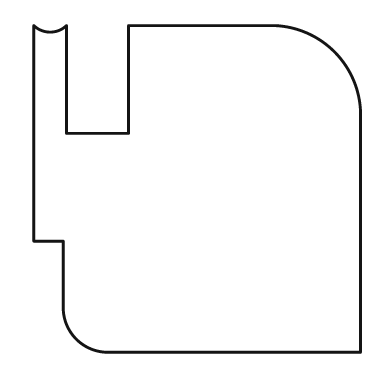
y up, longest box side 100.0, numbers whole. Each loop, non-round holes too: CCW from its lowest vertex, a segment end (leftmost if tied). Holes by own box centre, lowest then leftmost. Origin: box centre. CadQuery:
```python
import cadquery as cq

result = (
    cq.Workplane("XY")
    .moveTo(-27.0, -50.0)
    .lineTo(50.0, -50.0)
    .lineTo(50.0, 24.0)
    .threePointArc((42.0, 42.0), (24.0, 50.0))
    .lineTo(-21.0, 50.0)
    .lineTo(-21.0, 17.0)
    .lineTo(-40.0, 17.0)
    .lineTo(-40.0, 50.0)
    .threePointArc((-45.0, 48.0), (-50.0, 50.0))
    .lineTo(-50.0, -16.0)
    .lineTo(-41.0, -16.0)
    .lineTo(-41.0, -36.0)
    .threePointArc((-37.0, -46.0), (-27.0, -50.0))
    .close()
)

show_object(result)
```